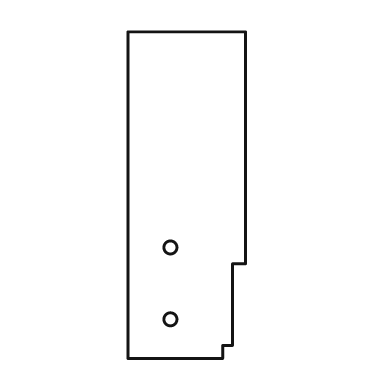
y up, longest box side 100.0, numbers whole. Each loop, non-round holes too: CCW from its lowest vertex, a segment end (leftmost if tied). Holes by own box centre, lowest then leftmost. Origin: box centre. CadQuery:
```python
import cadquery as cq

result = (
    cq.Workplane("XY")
    .moveTo(-18.0, -50.0)
    .lineTo(11.0, -50.0)
    .lineTo(11.0, -46.0)
    .lineTo(14.0, -46.0)
    .lineTo(14.0, -21.0)
    .lineTo(18.0, -21.0)
    .lineTo(18.0, 50.0)
    .lineTo(-18.0, 50.0)
    .close()
    .moveTo(-5.0, -38.0)
    .circle(2.0)
    .moveTo(-5.0, -16.0)
    .circle(2.0)
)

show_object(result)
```